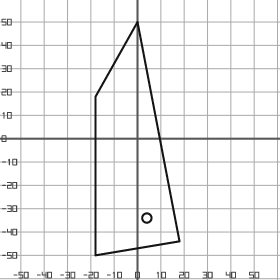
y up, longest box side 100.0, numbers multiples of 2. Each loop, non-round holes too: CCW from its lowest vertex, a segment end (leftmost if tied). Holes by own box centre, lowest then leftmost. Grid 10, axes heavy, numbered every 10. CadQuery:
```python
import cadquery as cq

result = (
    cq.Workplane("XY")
    .moveTo(-18.0, -50.0)
    .lineTo(18.0, -44.0)
    .lineTo(0.0, 50.0)
    .lineTo(-18.0, 18.0)
    .close()
    .moveTo(4.0, -34.0)
    .circle(2.0)
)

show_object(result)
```